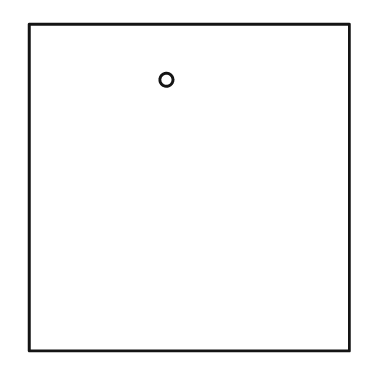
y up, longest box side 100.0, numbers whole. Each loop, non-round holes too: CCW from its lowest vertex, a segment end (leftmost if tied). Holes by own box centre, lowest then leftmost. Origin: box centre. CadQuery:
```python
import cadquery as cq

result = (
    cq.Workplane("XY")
    .moveTo(-49.0, -50.0)
    .lineTo(49.0, -50.0)
    .lineTo(49.0, 50.0)
    .lineTo(-49.0, 50.0)
    .close()
    .moveTo(-7.0, 33.0)
    .circle(2.0)
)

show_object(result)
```